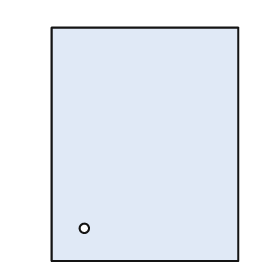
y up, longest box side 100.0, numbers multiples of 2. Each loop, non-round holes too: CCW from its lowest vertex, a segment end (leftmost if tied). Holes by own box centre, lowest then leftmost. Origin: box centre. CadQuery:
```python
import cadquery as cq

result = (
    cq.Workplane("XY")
    .moveTo(-40.0, -50.0)
    .lineTo(40.0, -50.0)
    .lineTo(40.0, 50.0)
    .lineTo(-40.0, 50.0)
    .close()
    .moveTo(-26.0, -36.0)
    .circle(2.0)
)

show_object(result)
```